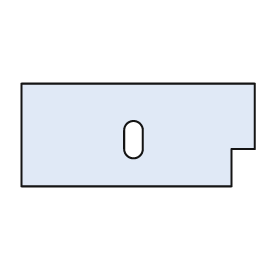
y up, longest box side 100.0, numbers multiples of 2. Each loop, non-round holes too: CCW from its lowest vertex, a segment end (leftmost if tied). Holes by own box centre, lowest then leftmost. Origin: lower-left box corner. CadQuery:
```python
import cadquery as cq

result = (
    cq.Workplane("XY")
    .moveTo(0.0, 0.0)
    .lineTo(90.0, 0.0)
    .lineTo(90.0, 16.0)
    .lineTo(100.0, 16.0)
    .lineTo(100.0, 44.0)
    .lineTo(0.0, 44.0)
    .close()
    .moveTo(44.0, 16.0)
    .threePointArc((48.0, 12.0), (52.0, 16.0))
    .lineTo(52.0, 24.0)
    .threePointArc((48.0, 28.0), (44.0, 24.0))
    .close()
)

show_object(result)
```